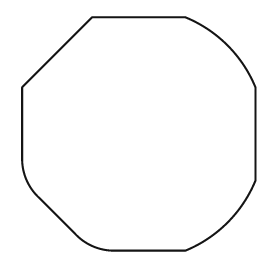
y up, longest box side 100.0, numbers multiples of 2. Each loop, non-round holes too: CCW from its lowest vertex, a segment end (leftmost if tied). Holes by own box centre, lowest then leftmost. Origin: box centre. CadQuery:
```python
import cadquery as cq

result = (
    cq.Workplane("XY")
    .moveTo(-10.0, -50.0)
    .lineTo(20.0, -50.0)
    .threePointArc((38.0, -38.0), (50.0, -20.0))
    .lineTo(50.0, 20.0)
    .threePointArc((38.0, 38.0), (20.0, 50.0))
    .lineTo(-20.0, 50.0)
    .lineTo(-50.0, 20.0)
    .lineTo(-50.0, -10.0)
    .threePointArc((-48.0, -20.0), (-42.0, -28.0))
    .lineTo(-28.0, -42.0)
    .threePointArc((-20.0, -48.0), (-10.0, -50.0))
    .close()
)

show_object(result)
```